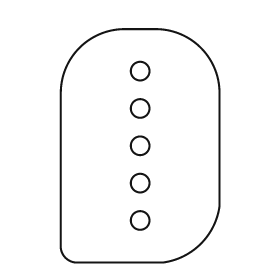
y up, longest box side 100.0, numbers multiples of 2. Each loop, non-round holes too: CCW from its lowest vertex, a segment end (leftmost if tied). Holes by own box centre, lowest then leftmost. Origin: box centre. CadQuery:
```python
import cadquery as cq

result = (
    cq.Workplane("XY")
    .moveTo(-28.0, -50.0)
    .lineTo(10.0, -50.0)
    .threePointArc((26.0, -42.0), (34.0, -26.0))
    .lineTo(34.0, 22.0)
    .threePointArc((26.0, 42.0), (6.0, 50.0))
    .lineTo(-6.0, 50.0)
    .threePointArc((-26.0, 42.0), (-34.0, 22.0))
    .lineTo(-34.0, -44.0)
    .threePointArc((-32.0, -48.0), (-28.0, -50.0))
    .close()
    .moveTo(0.0, -32.0)
    .circle(4.0)
    .moveTo(0.0, -16.0)
    .circle(4.0)
    .moveTo(0.0, 0.0)
    .circle(4.0)
    .moveTo(0.0, 16.0)
    .circle(4.0)
    .moveTo(0.0, 32.0)
    .circle(4.0)
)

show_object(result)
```